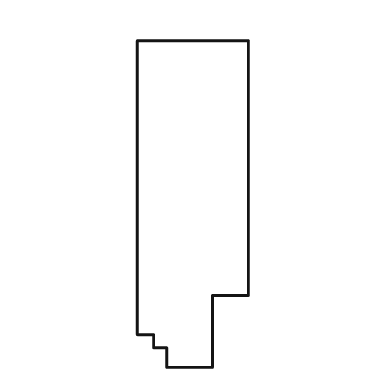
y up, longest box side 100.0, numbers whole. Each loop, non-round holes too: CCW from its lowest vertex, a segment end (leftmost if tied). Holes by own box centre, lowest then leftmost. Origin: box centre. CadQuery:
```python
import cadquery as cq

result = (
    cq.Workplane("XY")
    .moveTo(-8.0, -50.0)
    .lineTo(6.0, -50.0)
    .lineTo(6.0, -28.0)
    .lineTo(17.0, -28.0)
    .lineTo(17.0, 50.0)
    .lineTo(-17.0, 50.0)
    .lineTo(-17.0, -40.0)
    .lineTo(-12.0, -40.0)
    .lineTo(-12.0, -44.0)
    .lineTo(-8.0, -44.0)
    .close()
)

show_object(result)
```